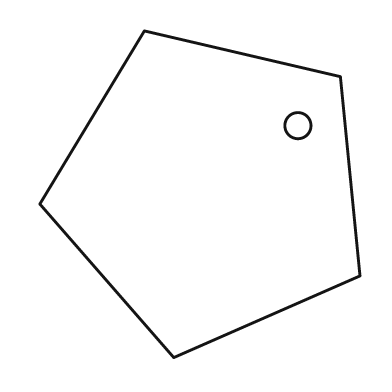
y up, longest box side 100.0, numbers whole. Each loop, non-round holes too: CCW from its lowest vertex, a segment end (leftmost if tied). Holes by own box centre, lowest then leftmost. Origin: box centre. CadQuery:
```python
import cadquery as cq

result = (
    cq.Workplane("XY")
    .moveTo(-8.0, -50.0)
    .lineTo(49.0, -25.0)
    .lineTo(43.0, 36.0)
    .lineTo(-17.0, 50.0)
    .lineTo(-49.0, -3.0)
    .close()
    .moveTo(30.0, 21.0)
    .circle(4.0)
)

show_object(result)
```